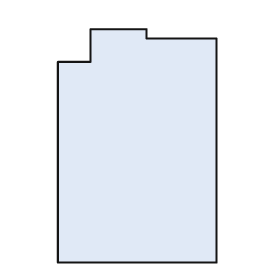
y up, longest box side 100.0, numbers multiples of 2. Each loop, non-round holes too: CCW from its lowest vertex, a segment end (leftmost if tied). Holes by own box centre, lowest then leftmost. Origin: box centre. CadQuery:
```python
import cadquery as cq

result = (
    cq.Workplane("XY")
    .moveTo(-34.0, -50.0)
    .lineTo(34.0, -50.0)
    .lineTo(34.0, 46.0)
    .lineTo(4.0, 46.0)
    .lineTo(4.0, 50.0)
    .lineTo(-20.0, 50.0)
    .lineTo(-20.0, 36.0)
    .lineTo(-34.0, 36.0)
    .close()
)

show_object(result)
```